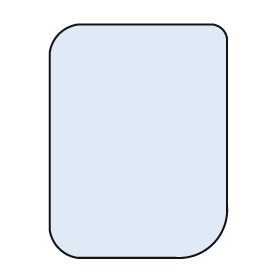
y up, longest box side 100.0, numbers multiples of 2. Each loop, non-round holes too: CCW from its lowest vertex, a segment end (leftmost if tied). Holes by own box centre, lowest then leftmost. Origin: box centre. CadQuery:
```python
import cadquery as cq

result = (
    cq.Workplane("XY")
    .moveTo(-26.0, -50.0)
    .lineTo(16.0, -50.0)
    .threePointArc((32.0, -44.0), (38.0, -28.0))
    .lineTo(38.0, 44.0)
    .threePointArc((36.0, 48.0), (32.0, 50.0))
    .lineTo(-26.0, 50.0)
    .threePointArc((-34.0, 46.0), (-38.0, 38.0))
    .lineTo(-38.0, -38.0)
    .threePointArc((-34.0, -46.0), (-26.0, -50.0))
    .close()
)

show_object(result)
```